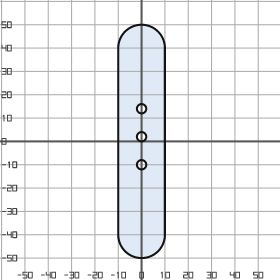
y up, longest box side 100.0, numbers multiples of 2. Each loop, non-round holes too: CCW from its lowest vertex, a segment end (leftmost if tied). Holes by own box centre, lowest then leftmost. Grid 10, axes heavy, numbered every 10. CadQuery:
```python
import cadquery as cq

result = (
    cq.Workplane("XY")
    .moveTo(-10.0, -40.0)
    .threePointArc((0.0, -50.0), (10.0, -40.0))
    .lineTo(10.0, 40.0)
    .threePointArc((0.0, 50.0), (-10.0, 40.0))
    .close()
    .moveTo(0.0, -10.0)
    .circle(2.0)
    .moveTo(0.0, 2.0)
    .circle(2.0)
    .moveTo(0.0, 14.0)
    .circle(2.0)
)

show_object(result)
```